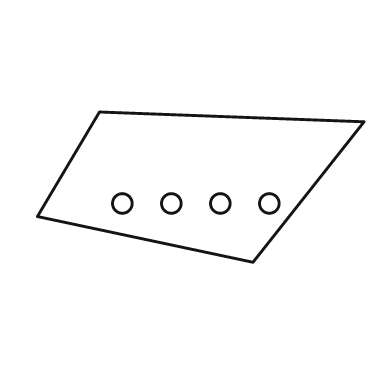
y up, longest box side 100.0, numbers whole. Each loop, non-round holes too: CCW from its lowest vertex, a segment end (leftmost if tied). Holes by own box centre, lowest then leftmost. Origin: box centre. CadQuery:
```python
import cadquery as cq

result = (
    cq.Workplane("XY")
    .moveTo(16.0, -23.0)
    .lineTo(50.0, 20.0)
    .lineTo(-31.0, 23.0)
    .lineTo(-50.0, -9.0)
    .close()
    .moveTo(-24.0, -5.0)
    .circle(3.0)
    .moveTo(-9.0, -5.0)
    .circle(3.0)
    .moveTo(6.0, -5.0)
    .circle(3.0)
    .moveTo(21.0, -5.0)
    .circle(3.0)
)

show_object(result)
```